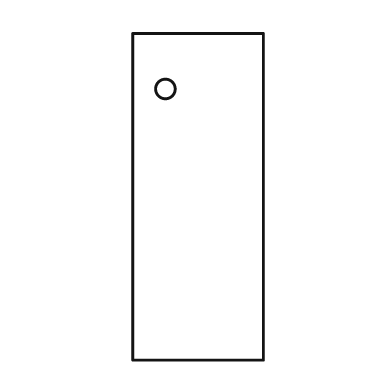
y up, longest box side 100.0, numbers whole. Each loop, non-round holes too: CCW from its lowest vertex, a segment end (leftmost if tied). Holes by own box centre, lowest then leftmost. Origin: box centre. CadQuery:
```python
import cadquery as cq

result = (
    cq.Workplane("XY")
    .moveTo(-20.0, -50.0)
    .lineTo(20.0, -50.0)
    .lineTo(20.0, 50.0)
    .lineTo(-20.0, 50.0)
    .close()
    .moveTo(-10.0, 33.0)
    .circle(3.0)
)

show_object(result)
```